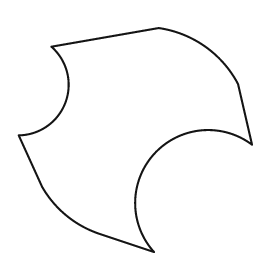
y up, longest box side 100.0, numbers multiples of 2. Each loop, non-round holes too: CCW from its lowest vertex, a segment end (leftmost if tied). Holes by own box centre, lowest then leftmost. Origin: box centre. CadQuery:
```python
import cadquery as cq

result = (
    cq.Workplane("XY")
    .moveTo(8.0, -48.0)
    .threePointArc((8.0, -6.0), (50.0, -2.0))
    .lineTo(44.0, 24.0)
    .threePointArc((30.0, 40.0), (10.0, 48.0))
    .lineTo(-36.0, 40.0)
    .threePointArc((-30.0, 16.0), (-50.0, 2.0))
    .lineTo(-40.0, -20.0)
    .threePointArc((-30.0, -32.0), (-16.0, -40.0))
    .close()
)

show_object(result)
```